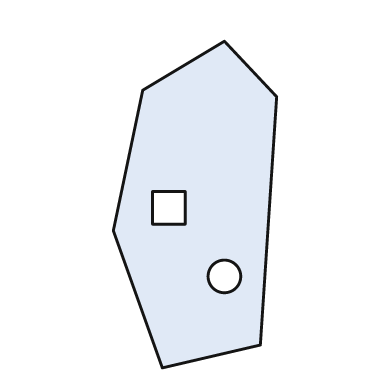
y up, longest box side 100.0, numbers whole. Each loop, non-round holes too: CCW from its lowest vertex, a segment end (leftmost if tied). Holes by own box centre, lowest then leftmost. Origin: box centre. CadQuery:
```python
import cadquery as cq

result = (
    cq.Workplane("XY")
    .moveTo(-10.0, -50.0)
    .lineTo(20.0, -43.0)
    .lineTo(25.0, 33.0)
    .lineTo(9.0, 50.0)
    .lineTo(-16.0, 35.0)
    .lineTo(-25.0, -8.0)
    .close()
    .moveTo(9.0, -22.0)
    .circle(5.0)
    .moveTo(-13.0, -6.0)
    .lineTo(-3.0, -6.0)
    .lineTo(-3.0, 4.0)
    .lineTo(-13.0, 4.0)
    .close()
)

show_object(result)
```